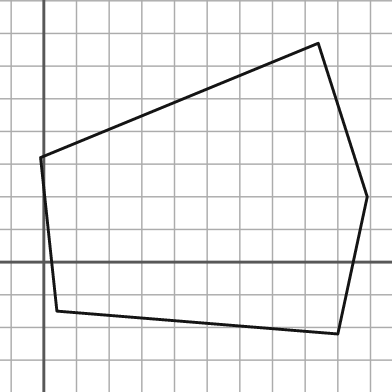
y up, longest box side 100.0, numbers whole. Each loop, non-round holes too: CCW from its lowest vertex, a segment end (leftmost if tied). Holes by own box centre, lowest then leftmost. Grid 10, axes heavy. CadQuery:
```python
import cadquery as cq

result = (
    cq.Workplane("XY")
    .moveTo(90.0, -22.0)
    .lineTo(99.0, 20.0)
    .lineTo(84.0, 67.0)
    .lineTo(-1.0, 32.0)
    .lineTo(4.0, -15.0)
    .close()
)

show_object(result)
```